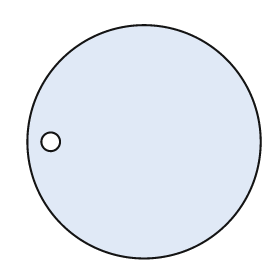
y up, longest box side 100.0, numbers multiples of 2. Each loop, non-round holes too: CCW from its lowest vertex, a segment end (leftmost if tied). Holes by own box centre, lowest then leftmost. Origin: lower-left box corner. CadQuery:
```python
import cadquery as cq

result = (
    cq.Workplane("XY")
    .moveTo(50.0, 50.0)
    .circle(50.0)
    .moveTo(10.0, 50.0)
    .circle(4.0)
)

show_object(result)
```